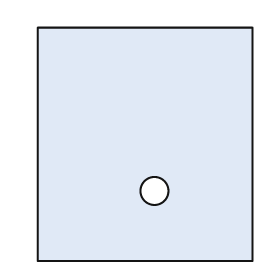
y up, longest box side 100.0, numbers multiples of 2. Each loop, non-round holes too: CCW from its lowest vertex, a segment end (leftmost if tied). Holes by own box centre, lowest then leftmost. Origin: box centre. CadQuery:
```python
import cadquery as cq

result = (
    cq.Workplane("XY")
    .moveTo(-46.0, -50.0)
    .lineTo(46.0, -50.0)
    .lineTo(46.0, 50.0)
    .lineTo(-46.0, 50.0)
    .close()
    .moveTo(4.0, -20.0)
    .circle(6.0)
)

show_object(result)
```